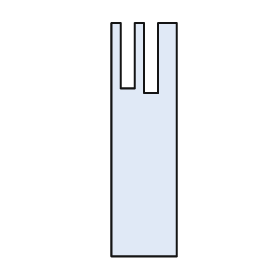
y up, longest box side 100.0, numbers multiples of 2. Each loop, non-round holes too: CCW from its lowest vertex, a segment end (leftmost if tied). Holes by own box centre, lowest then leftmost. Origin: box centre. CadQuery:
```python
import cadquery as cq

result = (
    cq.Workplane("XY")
    .moveTo(-14.0, -50.0)
    .lineTo(14.0, -50.0)
    .lineTo(14.0, 50.0)
    .lineTo(6.0, 50.0)
    .lineTo(6.0, 20.0)
    .lineTo(0.0, 20.0)
    .lineTo(0.0, 50.0)
    .lineTo(-4.0, 50.0)
    .lineTo(-4.0, 22.0)
    .lineTo(-10.0, 22.0)
    .lineTo(-10.0, 50.0)
    .lineTo(-14.0, 50.0)
    .close()
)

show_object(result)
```